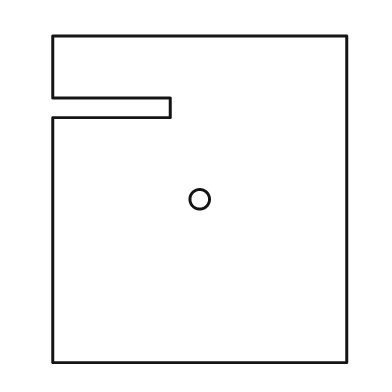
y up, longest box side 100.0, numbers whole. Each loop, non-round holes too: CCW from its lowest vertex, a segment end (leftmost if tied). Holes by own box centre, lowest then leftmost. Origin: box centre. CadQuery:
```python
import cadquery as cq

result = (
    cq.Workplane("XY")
    .moveTo(-45.0, -50.0)
    .lineTo(45.0, -50.0)
    .lineTo(45.0, 50.0)
    .lineTo(-45.0, 50.0)
    .lineTo(-45.0, 31.0)
    .lineTo(-9.0, 31.0)
    .lineTo(-9.0, 25.0)
    .lineTo(-45.0, 25.0)
    .close()
    .moveTo(0.0, 0.0)
    .circle(3.0)
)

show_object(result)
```